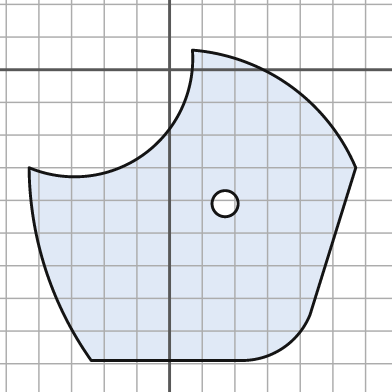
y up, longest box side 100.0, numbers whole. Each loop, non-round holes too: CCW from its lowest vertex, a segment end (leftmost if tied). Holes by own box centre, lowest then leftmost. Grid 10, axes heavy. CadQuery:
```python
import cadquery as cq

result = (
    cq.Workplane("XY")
    .moveTo(-24.0, -89.0)
    .lineTo(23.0, -89.0)
    .threePointArc((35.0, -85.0), (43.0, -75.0))
    .lineTo(57.0, -30.0)
    .threePointArc((37.0, -5.0), (7.0, 6.0))
    .threePointArc((-8.0, -26.0), (-43.0, -30.0))
    .threePointArc((-38.0, -61.0), (-24.0, -89.0))
    .close()
    .moveTo(17.0, -41.0)
    .circle(4.0)
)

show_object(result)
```